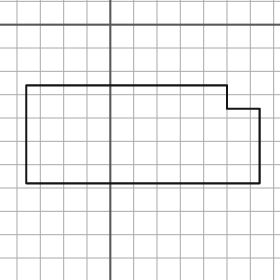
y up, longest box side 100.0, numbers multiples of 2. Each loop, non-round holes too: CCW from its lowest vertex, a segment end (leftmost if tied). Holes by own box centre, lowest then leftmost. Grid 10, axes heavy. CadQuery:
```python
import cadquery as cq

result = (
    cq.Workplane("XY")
    .moveTo(-36.0, -68.0)
    .lineTo(64.0, -68.0)
    .lineTo(64.0, -36.0)
    .lineTo(50.0, -36.0)
    .lineTo(50.0, -26.0)
    .lineTo(-36.0, -26.0)
    .close()
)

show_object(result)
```